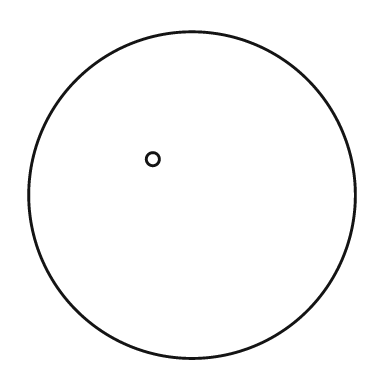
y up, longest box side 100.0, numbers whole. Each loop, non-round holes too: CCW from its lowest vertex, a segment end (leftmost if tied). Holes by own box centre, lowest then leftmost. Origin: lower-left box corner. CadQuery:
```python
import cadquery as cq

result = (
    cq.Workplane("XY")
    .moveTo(50.0, 50.0)
    .circle(50.0)
    .moveTo(38.0, 61.0)
    .circle(2.0)
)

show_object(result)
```